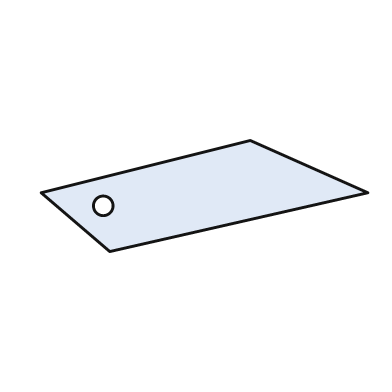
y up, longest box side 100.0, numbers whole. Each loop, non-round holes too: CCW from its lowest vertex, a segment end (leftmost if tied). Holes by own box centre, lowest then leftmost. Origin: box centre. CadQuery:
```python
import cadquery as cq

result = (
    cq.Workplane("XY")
    .moveTo(-29.0, -17.0)
    .lineTo(50.0, 1.0)
    .lineTo(14.0, 17.0)
    .lineTo(-50.0, 1.0)
    .close()
    .moveTo(-31.0, -3.0)
    .circle(3.0)
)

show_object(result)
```